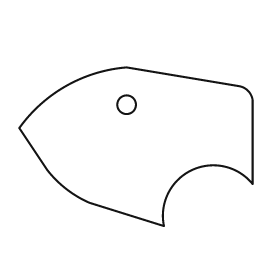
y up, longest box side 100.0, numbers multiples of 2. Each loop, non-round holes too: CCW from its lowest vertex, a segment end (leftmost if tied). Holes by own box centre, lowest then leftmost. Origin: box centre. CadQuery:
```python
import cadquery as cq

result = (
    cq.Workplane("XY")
    .moveTo(12.0, -34.0)
    .threePointArc((24.0, -10.0), (50.0, -16.0))
    .lineTo(50.0, 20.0)
    .threePointArc((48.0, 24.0), (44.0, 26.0))
    .lineTo(-4.0, 34.0)
    .threePointArc((-30.0, 26.0), (-50.0, 8.0))
    .lineTo(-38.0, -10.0)
    .threePointArc((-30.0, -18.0), (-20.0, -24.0))
    .close()
    .moveTo(-4.0, 18.0)
    .circle(4.0)
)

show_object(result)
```